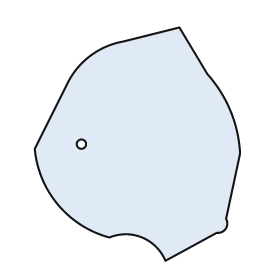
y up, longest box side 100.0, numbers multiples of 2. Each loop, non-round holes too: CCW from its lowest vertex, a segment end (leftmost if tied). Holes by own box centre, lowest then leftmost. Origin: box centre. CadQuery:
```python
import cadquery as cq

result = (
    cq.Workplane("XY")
    .moveTo(12.0, -50.0)
    .lineTo(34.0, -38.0)
    .threePointArc((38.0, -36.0), (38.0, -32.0))
    .lineTo(44.0, -4.0)
    .threePointArc((40.0, 14.0), (30.0, 30.0))
    .lineTo(18.0, 50.0)
    .lineTo(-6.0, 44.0)
    .threePointArc((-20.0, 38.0), (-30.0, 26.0))
    .lineTo(-44.0, -2.0)
    .threePointArc((-34.0, -26.0), (-12.0, -40.0))
    .threePointArc((2.0, -40.0), (12.0, -50.0))
    .close()
    .moveTo(-24.0, 0.0)
    .circle(2.0)
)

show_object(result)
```